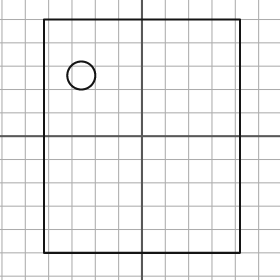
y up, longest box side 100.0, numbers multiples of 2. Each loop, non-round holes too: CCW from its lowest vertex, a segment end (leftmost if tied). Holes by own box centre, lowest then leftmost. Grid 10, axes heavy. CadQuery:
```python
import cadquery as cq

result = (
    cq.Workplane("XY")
    .moveTo(-42.0, -50.0)
    .lineTo(42.0, -50.0)
    .lineTo(42.0, 50.0)
    .lineTo(-42.0, 50.0)
    .close()
    .moveTo(-26.0, 26.0)
    .circle(6.0)
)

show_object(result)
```